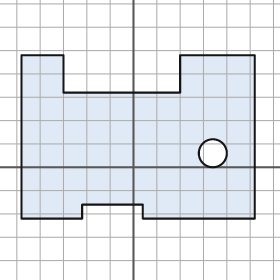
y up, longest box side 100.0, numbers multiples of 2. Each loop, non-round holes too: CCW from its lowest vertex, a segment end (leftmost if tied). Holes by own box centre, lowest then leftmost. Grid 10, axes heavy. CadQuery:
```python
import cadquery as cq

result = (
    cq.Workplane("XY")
    .moveTo(-48.0, -22.0)
    .lineTo(-22.0, -22.0)
    .lineTo(-22.0, -16.0)
    .lineTo(4.0, -16.0)
    .lineTo(4.0, -22.0)
    .lineTo(52.0, -22.0)
    .lineTo(52.0, 48.0)
    .lineTo(20.0, 48.0)
    .lineTo(20.0, 32.0)
    .lineTo(-30.0, 32.0)
    .lineTo(-30.0, 48.0)
    .lineTo(-48.0, 48.0)
    .close()
    .moveTo(34.0, 6.0)
    .circle(6.0)
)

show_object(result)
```